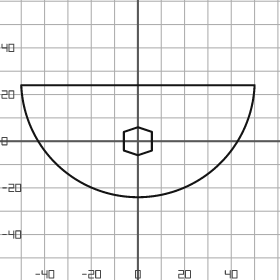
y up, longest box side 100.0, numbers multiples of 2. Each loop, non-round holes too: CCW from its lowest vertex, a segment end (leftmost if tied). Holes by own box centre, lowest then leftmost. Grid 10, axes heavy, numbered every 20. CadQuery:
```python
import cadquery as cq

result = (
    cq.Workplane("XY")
    .moveTo(-50.0, 24.0)
    .threePointArc((0.0, -24.0), (50.0, 24.0))
    .close()
    .moveTo(0.0, -6.0)
    .lineTo(6.0, -4.0)
    .lineTo(6.0, 4.0)
    .lineTo(0.0, 6.0)
    .lineTo(-6.0, 4.0)
    .lineTo(-6.0, -4.0)
    .close()
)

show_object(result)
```